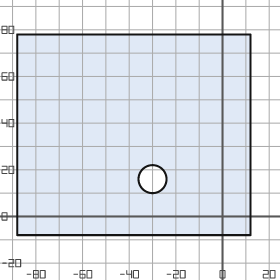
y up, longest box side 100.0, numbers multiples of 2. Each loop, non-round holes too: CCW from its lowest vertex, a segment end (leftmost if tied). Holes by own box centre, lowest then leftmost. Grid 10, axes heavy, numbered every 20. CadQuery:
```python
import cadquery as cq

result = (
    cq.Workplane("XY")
    .moveTo(-88.0, -8.0)
    .lineTo(12.0, -8.0)
    .lineTo(12.0, 78.0)
    .lineTo(-88.0, 78.0)
    .close()
    .moveTo(-30.0, 16.0)
    .circle(6.0)
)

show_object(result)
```